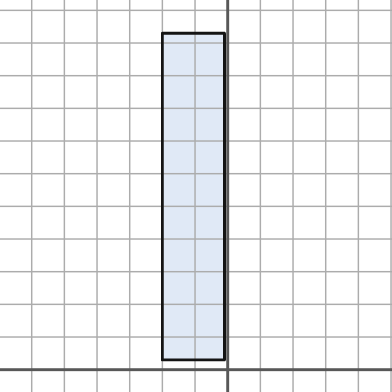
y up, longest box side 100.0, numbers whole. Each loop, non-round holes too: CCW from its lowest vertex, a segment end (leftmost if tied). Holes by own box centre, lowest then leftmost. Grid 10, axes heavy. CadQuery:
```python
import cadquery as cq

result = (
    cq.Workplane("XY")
    .moveTo(-20.0, 3.0)
    .lineTo(-1.0, 3.0)
    .lineTo(-1.0, 103.0)
    .lineTo(-20.0, 103.0)
    .close()
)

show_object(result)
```